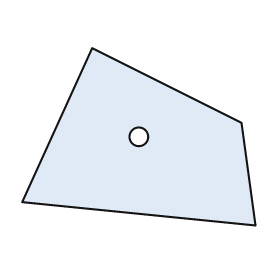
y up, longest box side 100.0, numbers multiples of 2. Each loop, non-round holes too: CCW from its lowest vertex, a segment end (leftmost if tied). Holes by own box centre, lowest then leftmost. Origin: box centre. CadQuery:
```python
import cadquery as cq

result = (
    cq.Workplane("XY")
    .moveTo(50.0, -38.0)
    .lineTo(44.0, 6.0)
    .lineTo(-20.0, 38.0)
    .lineTo(-50.0, -28.0)
    .close()
    .moveTo(0.0, 0.0)
    .circle(4.0)
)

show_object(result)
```